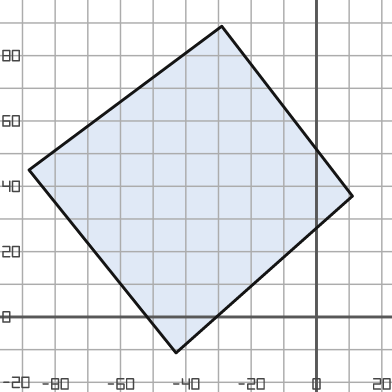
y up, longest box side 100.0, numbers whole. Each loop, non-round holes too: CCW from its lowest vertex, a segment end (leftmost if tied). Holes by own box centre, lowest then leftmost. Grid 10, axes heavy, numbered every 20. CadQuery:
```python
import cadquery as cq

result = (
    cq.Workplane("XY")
    .moveTo(-43.0, -11.0)
    .lineTo(11.0, 37.0)
    .lineTo(-29.0, 89.0)
    .lineTo(-88.0, 45.0)
    .close()
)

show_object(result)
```